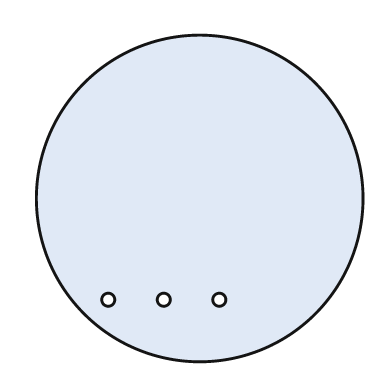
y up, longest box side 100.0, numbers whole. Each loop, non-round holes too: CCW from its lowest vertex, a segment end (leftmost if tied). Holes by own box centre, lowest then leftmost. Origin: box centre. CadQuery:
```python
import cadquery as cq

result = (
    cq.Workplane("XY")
    .moveTo(0.0, 0.0)
    .circle(50.0)
    .moveTo(-28.0, -31.0)
    .circle(2.0)
    .moveTo(-11.0, -31.0)
    .circle(2.0)
    .moveTo(6.0, -31.0)
    .circle(2.0)
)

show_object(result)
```